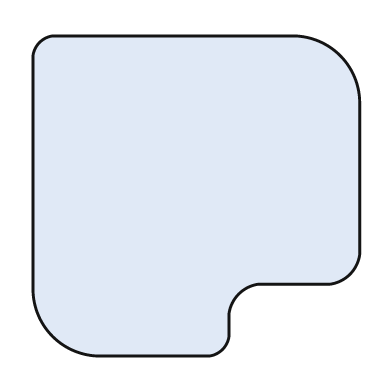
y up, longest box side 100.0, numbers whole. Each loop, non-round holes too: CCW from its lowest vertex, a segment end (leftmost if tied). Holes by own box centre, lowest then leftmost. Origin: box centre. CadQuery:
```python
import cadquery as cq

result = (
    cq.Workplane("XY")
    .moveTo(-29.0, -49.0)
    .lineTo(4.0, -49.0)
    .threePointArc((8.0, -47.0), (10.0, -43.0))
    .lineTo(10.0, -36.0)
    .threePointArc((13.0, -30.0), (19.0, -27.0))
    .lineTo(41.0, -27.0)
    .threePointArc((47.0, -24.0), (50.0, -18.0))
    .lineTo(50.0, 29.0)
    .threePointArc((44.0, 43.0), (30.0, 49.0))
    .lineTo(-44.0, 49.0)
    .threePointArc((-48.0, 47.0), (-50.0, 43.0))
    .lineTo(-50.0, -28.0)
    .threePointArc((-44.0, -43.0), (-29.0, -49.0))
    .close()
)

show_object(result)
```